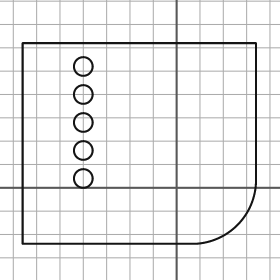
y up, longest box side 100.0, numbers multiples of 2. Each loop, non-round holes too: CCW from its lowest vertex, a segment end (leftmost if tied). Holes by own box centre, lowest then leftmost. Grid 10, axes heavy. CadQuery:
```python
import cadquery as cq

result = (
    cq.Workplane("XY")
    .moveTo(-66.0, -24.0)
    .lineTo(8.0, -24.0)
    .threePointArc((26.0, -16.0), (34.0, 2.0))
    .lineTo(34.0, 62.0)
    .lineTo(-66.0, 62.0)
    .close()
    .moveTo(-40.0, 4.0)
    .circle(4.0)
    .moveTo(-40.0, 16.0)
    .circle(4.0)
    .moveTo(-40.0, 28.0)
    .circle(4.0)
    .moveTo(-40.0, 40.0)
    .circle(4.0)
    .moveTo(-40.0, 52.0)
    .circle(4.0)
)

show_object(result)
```